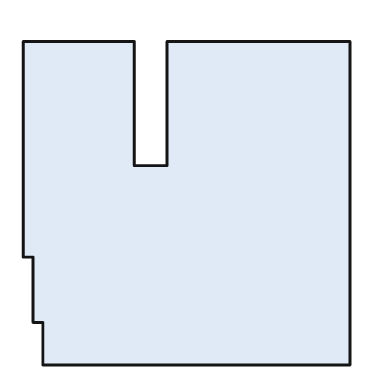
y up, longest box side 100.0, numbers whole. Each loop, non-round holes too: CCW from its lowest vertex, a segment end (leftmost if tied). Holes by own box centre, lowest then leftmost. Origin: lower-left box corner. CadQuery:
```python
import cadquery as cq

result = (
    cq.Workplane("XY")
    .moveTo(6.0, 0.0)
    .lineTo(100.0, 0.0)
    .lineTo(100.0, 99.0)
    .lineTo(44.0, 99.0)
    .lineTo(44.0, 61.0)
    .lineTo(34.0, 61.0)
    .lineTo(34.0, 99.0)
    .lineTo(0.0, 99.0)
    .lineTo(0.0, 33.0)
    .lineTo(3.0, 33.0)
    .lineTo(3.0, 13.0)
    .lineTo(6.0, 13.0)
    .close()
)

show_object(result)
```